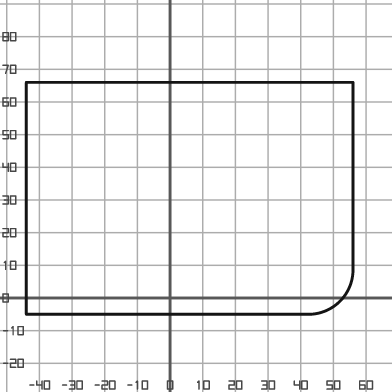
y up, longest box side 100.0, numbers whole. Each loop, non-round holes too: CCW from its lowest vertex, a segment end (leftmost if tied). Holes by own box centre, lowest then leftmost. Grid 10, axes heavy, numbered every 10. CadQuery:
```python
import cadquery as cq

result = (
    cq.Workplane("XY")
    .moveTo(-44.0, -5.0)
    .lineTo(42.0, -5.0)
    .threePointArc((52.0, -1.0), (56.0, 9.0))
    .lineTo(56.0, 66.0)
    .lineTo(-44.0, 66.0)
    .close()
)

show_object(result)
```